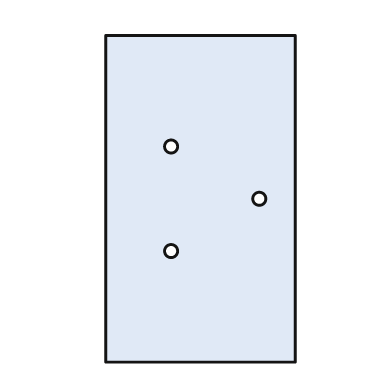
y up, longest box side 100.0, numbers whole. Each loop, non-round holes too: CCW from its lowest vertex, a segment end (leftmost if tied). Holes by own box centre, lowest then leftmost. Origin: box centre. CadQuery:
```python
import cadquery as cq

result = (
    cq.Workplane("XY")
    .moveTo(-29.0, -50.0)
    .lineTo(29.0, -50.0)
    .lineTo(29.0, 50.0)
    .lineTo(-29.0, 50.0)
    .close()
    .moveTo(-9.0, -16.0)
    .circle(2.0)
    .moveTo(18.0, 0.0)
    .circle(2.0)
    .moveTo(-9.0, 16.0)
    .circle(2.0)
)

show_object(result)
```